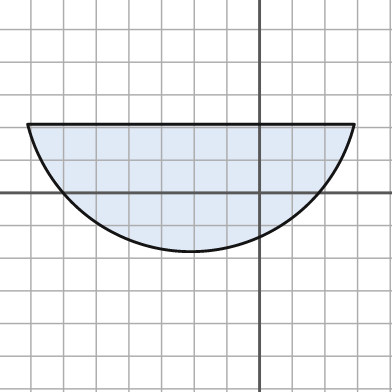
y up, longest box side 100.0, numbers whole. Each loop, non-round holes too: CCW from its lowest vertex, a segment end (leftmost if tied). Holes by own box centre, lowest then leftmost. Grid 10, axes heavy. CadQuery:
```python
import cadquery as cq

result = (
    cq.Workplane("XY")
    .moveTo(-71.0, 21.0)
    .threePointArc((-21.0, -18.0), (29.0, 21.0))
    .close()
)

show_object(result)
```